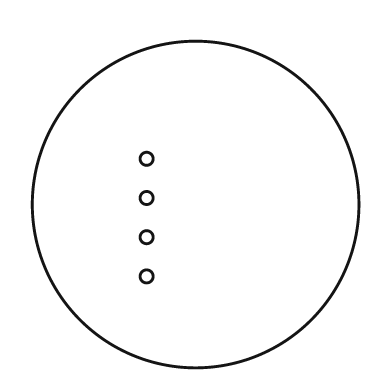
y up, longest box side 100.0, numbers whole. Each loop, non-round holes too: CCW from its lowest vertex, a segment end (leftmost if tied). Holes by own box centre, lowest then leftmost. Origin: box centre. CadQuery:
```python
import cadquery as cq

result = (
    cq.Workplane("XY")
    .moveTo(0.0, 0.0)
    .circle(50.0)
    .moveTo(-15.0, -22.0)
    .circle(2.0)
    .moveTo(-15.0, -10.0)
    .circle(2.0)
    .moveTo(-15.0, 2.0)
    .circle(2.0)
    .moveTo(-15.0, 14.0)
    .circle(2.0)
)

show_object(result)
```